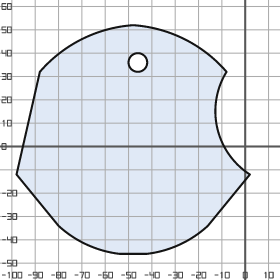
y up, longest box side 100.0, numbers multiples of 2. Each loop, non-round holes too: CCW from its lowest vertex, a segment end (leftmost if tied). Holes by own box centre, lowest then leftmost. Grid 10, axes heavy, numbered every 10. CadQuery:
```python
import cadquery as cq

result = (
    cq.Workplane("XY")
    .moveTo(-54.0, -46.0)
    .lineTo(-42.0, -46.0)
    .threePointArc((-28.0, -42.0), (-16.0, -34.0))
    .lineTo(2.0, -12.0)
    .threePointArc((-12.0, 8.0), (-8.0, 32.0))
    .threePointArc((-26.0, 46.0), (-48.0, 52.0))
    .threePointArc((-70.0, 46.0), (-88.0, 32.0))
    .lineTo(-98.0, -12.0)
    .lineTo(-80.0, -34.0)
    .threePointArc((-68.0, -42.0), (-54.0, -46.0))
    .close()
    .moveTo(-46.0, 36.0)
    .circle(4.0)
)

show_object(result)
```